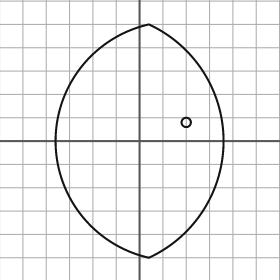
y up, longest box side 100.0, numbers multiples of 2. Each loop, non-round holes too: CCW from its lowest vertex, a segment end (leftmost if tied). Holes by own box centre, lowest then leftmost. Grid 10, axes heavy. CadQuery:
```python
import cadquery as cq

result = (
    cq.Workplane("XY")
    .moveTo(4.0, -50.0)
    .threePointArc((36.0, 0.0), (4.0, 50.0))
    .threePointArc((-36.0, 0.0), (4.0, -50.0))
    .close()
    .moveTo(20.0, 8.0)
    .circle(2.0)
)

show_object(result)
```